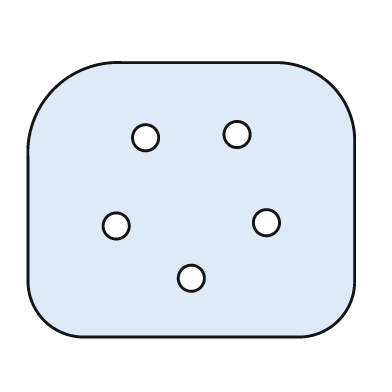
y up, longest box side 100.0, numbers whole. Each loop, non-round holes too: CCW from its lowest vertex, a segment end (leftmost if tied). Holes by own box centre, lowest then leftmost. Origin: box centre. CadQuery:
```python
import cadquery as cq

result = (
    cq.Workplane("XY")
    .moveTo(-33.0, -42.0)
    .lineTo(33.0, -42.0)
    .threePointArc((45.0, -37.0), (50.0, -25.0))
    .lineTo(50.0, 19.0)
    .threePointArc((43.0, 35.0), (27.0, 42.0))
    .lineTo(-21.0, 42.0)
    .threePointArc((-42.0, 34.0), (-50.0, 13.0))
    .lineTo(-50.0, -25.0)
    .threePointArc((-45.0, -37.0), (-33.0, -42.0))
    .close()
    .moveTo(0.0, -24.0)
    .circle(4.0)
    .moveTo(-23.0, -8.0)
    .circle(4.0)
    .moveTo(23.0, -7.0)
    .circle(4.0)
    .moveTo(-14.0, 19.0)
    .circle(4.0)
    .moveTo(14.0, 20.0)
    .circle(4.0)
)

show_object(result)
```